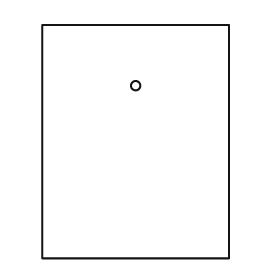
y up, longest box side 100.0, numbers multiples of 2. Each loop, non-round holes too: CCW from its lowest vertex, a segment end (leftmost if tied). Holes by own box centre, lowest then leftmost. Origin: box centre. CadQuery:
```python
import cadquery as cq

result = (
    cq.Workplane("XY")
    .moveTo(-40.0, -50.0)
    .lineTo(40.0, -50.0)
    .lineTo(40.0, 50.0)
    .lineTo(-40.0, 50.0)
    .close()
    .moveTo(0.0, 24.0)
    .circle(2.0)
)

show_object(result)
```